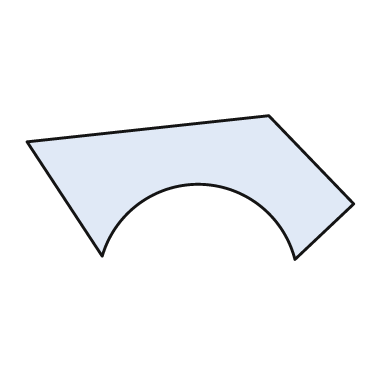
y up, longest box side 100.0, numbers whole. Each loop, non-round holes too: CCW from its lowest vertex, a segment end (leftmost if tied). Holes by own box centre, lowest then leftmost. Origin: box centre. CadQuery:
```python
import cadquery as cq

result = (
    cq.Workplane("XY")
    .moveTo(32.0, -22.0)
    .lineTo(50.0, -5.0)
    .lineTo(24.0, 22.0)
    .lineTo(-50.0, 14.0)
    .lineTo(-27.0, -21.0)
    .threePointArc((3.0, 1.0), (32.0, -22.0))
    .close()
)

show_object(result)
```